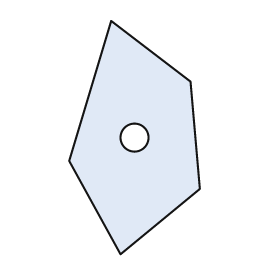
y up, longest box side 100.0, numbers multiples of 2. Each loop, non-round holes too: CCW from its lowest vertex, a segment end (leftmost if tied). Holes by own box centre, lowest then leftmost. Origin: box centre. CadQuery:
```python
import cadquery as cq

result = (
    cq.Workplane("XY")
    .moveTo(-6.0, -50.0)
    .lineTo(28.0, -22.0)
    .lineTo(24.0, 24.0)
    .lineTo(-10.0, 50.0)
    .lineTo(-28.0, -10.0)
    .close()
    .moveTo(0.0, 0.0)
    .circle(6.0)
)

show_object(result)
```